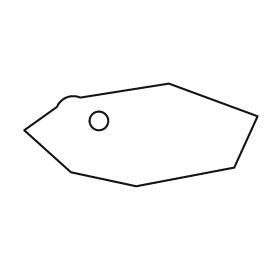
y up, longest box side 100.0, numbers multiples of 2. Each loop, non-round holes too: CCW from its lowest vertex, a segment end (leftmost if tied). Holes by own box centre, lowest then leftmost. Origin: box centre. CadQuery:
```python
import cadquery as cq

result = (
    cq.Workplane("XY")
    .moveTo(-2.0, -22.0)
    .lineTo(40.0, -14.0)
    .lineTo(50.0, 8.0)
    .lineTo(12.0, 22.0)
    .lineTo(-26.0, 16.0)
    .threePointArc((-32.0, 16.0), (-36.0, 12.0))
    .lineTo(-50.0, 2.0)
    .lineTo(-30.0, -16.0)
    .close()
    .moveTo(-18.0, 6.0)
    .circle(4.0)
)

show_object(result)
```